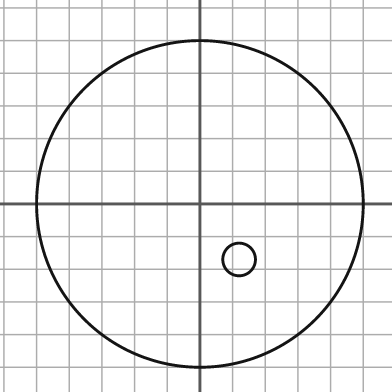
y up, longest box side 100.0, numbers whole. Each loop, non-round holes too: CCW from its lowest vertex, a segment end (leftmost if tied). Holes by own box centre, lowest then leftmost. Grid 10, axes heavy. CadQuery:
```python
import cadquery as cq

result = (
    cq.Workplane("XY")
    .moveTo(0.0, 0.0)
    .circle(50.0)
    .moveTo(12.0, -17.0)
    .circle(5.0)
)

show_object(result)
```